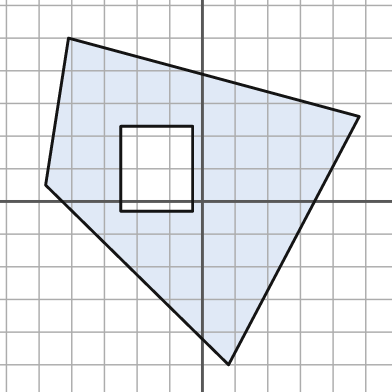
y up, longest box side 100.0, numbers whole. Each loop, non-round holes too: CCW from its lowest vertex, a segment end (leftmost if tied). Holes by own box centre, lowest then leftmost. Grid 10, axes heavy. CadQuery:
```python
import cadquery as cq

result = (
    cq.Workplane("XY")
    .moveTo(8.0, -50.0)
    .lineTo(48.0, 26.0)
    .lineTo(-41.0, 50.0)
    .lineTo(-48.0, 5.0)
    .close()
    .moveTo(-25.0, -3.0)
    .lineTo(-3.0, -3.0)
    .lineTo(-3.0, 23.0)
    .lineTo(-25.0, 23.0)
    .close()
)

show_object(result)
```